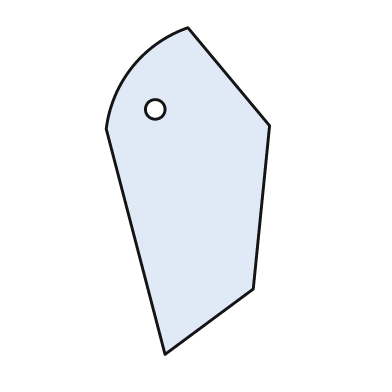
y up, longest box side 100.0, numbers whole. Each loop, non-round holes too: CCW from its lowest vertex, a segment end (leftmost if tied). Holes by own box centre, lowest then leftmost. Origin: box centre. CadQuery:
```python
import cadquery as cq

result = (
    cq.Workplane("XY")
    .moveTo(-7.0, -50.0)
    .lineTo(20.0, -30.0)
    .lineTo(25.0, 20.0)
    .lineTo(0.0, 50.0)
    .threePointArc((-17.0, 38.0), (-25.0, 19.0))
    .close()
    .moveTo(-10.0, 25.0)
    .circle(3.0)
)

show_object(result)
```